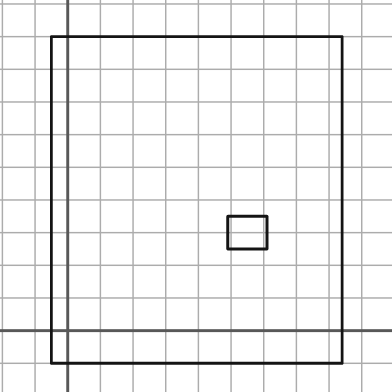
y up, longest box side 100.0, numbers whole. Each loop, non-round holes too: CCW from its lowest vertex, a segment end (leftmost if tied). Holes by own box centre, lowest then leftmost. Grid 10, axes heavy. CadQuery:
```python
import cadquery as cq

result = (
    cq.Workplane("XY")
    .moveTo(-5.0, -10.0)
    .lineTo(84.0, -10.0)
    .lineTo(84.0, 90.0)
    .lineTo(-5.0, 90.0)
    .close()
    .moveTo(49.0, 25.0)
    .lineTo(61.0, 25.0)
    .lineTo(61.0, 35.0)
    .lineTo(49.0, 35.0)
    .close()
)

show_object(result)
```